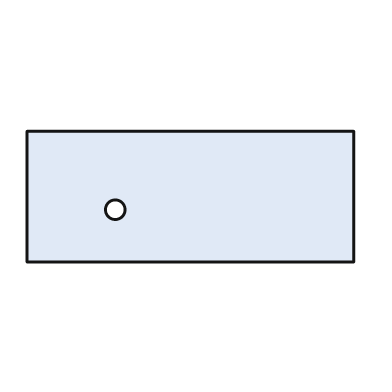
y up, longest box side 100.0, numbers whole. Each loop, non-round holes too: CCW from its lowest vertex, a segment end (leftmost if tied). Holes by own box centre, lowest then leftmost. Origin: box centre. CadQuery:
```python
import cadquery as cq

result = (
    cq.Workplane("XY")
    .moveTo(-50.0, -20.0)
    .lineTo(50.0, -20.0)
    .lineTo(50.0, 20.0)
    .lineTo(-50.0, 20.0)
    .close()
    .moveTo(-23.0, -4.0)
    .circle(3.0)
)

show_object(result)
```